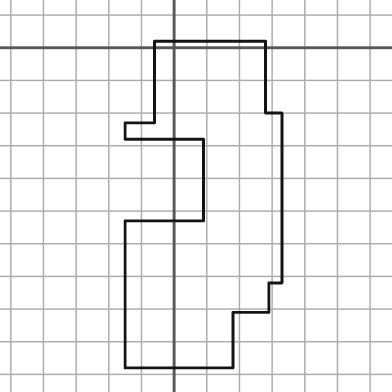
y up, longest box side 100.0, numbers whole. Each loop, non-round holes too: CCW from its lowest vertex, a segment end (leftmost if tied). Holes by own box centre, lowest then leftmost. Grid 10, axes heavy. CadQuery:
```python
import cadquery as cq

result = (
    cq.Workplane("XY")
    .moveTo(-15.0, -98.0)
    .lineTo(18.0, -98.0)
    .lineTo(18.0, -81.0)
    .lineTo(29.0, -81.0)
    .lineTo(29.0, -72.0)
    .lineTo(33.0, -72.0)
    .lineTo(33.0, -20.0)
    .lineTo(28.0, -20.0)
    .lineTo(28.0, 2.0)
    .lineTo(-6.0, 2.0)
    .lineTo(-6.0, -23.0)
    .lineTo(-15.0, -23.0)
    .lineTo(-15.0, -28.0)
    .lineTo(9.0, -28.0)
    .lineTo(9.0, -53.0)
    .lineTo(-15.0, -53.0)
    .close()
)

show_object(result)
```